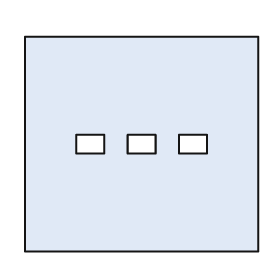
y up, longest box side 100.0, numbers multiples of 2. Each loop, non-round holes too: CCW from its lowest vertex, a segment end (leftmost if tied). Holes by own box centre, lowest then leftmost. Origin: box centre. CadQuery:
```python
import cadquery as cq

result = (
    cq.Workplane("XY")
    .moveTo(-50.0, -46.0)
    .lineTo(50.0, -46.0)
    .lineTo(50.0, 46.0)
    .lineTo(-50.0, 46.0)
    .close()
    .moveTo(-28.0, -4.0)
    .lineTo(-16.0, -4.0)
    .lineTo(-16.0, 4.0)
    .lineTo(-28.0, 4.0)
    .close()
    .moveTo(-6.0, -4.0)
    .lineTo(6.0, -4.0)
    .lineTo(6.0, 4.0)
    .lineTo(-6.0, 4.0)
    .close()
    .moveTo(16.0, -4.0)
    .lineTo(28.0, -4.0)
    .lineTo(28.0, 4.0)
    .lineTo(16.0, 4.0)
    .close()
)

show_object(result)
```